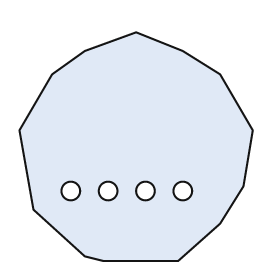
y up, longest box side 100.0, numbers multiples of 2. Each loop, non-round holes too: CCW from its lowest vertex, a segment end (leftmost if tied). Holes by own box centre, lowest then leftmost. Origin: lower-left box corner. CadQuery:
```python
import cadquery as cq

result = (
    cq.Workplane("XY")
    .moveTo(36.0, 0.0)
    .lineTo(68.0, 0.0)
    .lineTo(86.0, 16.0)
    .lineTo(96.0, 32.0)
    .lineTo(100.0, 56.0)
    .lineTo(86.0, 80.0)
    .lineTo(70.0, 90.0)
    .lineTo(50.0, 98.0)
    .lineTo(28.0, 90.0)
    .lineTo(14.0, 80.0)
    .lineTo(0.0, 56.0)
    .lineTo(6.0, 22.0)
    .lineTo(28.0, 2.0)
    .close()
    .moveTo(22.0, 30.0)
    .circle(4.0)
    .moveTo(38.0, 30.0)
    .circle(4.0)
    .moveTo(54.0, 30.0)
    .circle(4.0)
    .moveTo(70.0, 30.0)
    .circle(4.0)
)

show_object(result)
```